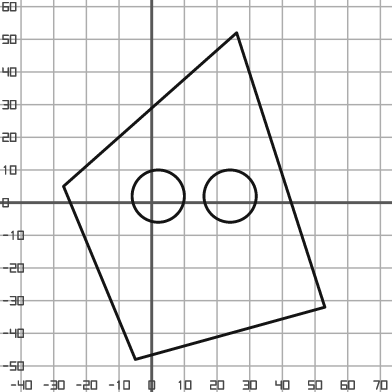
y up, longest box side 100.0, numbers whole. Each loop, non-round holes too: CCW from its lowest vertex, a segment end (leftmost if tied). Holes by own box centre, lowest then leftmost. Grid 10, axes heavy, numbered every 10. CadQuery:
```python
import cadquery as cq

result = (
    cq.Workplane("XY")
    .moveTo(-5.0, -48.0)
    .lineTo(53.0, -32.0)
    .lineTo(26.0, 52.0)
    .lineTo(-27.0, 5.0)
    .close()
    .moveTo(2.0, 2.0)
    .circle(8.0)
    .moveTo(24.0, 2.0)
    .circle(8.0)
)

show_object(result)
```